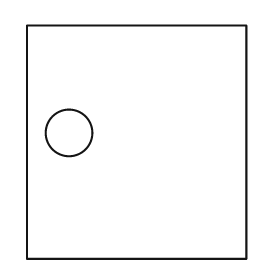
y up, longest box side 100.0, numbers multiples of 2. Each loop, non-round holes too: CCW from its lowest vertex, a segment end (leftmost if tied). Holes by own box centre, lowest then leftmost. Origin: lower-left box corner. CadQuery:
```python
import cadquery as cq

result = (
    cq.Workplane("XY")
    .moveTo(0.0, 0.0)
    .lineTo(94.0, 0.0)
    .lineTo(94.0, 100.0)
    .lineTo(0.0, 100.0)
    .close()
    .moveTo(18.0, 54.0)
    .circle(10.0)
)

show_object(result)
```